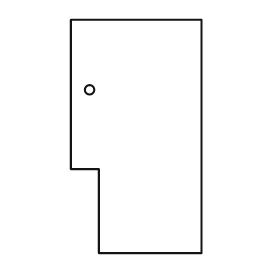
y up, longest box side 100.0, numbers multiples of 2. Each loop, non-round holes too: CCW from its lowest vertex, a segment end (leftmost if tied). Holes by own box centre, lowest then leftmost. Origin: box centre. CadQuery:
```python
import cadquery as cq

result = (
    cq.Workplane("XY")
    .moveTo(-16.0, -50.0)
    .lineTo(28.0, -50.0)
    .lineTo(28.0, 50.0)
    .lineTo(-28.0, 50.0)
    .lineTo(-28.0, -14.0)
    .lineTo(-16.0, -14.0)
    .close()
    .moveTo(-20.0, 20.0)
    .circle(2.0)
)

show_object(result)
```